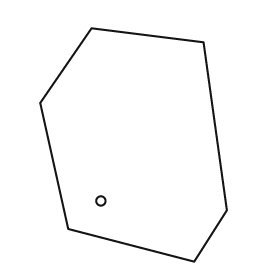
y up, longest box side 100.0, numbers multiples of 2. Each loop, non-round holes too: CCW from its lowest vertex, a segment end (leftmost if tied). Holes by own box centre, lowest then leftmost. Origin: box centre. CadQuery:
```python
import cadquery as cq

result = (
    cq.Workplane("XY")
    .moveTo(26.0, -50.0)
    .lineTo(40.0, -28.0)
    .lineTo(30.0, 44.0)
    .lineTo(-18.0, 50.0)
    .lineTo(-40.0, 18.0)
    .lineTo(-28.0, -36.0)
    .close()
    .moveTo(-14.0, -24.0)
    .circle(2.0)
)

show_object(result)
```